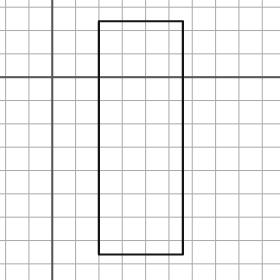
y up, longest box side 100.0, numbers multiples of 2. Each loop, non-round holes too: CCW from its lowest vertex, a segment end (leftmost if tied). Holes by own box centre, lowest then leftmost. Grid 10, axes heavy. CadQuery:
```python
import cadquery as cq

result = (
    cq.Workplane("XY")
    .moveTo(20.0, -76.0)
    .lineTo(56.0, -76.0)
    .lineTo(56.0, 24.0)
    .lineTo(20.0, 24.0)
    .close()
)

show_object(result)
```